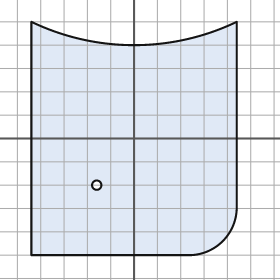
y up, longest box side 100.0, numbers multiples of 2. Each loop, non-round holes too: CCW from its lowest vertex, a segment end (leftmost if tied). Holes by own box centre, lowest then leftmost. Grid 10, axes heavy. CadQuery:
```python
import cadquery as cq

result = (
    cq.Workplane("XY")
    .moveTo(-44.0, -50.0)
    .lineTo(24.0, -50.0)
    .threePointArc((38.0, -44.0), (44.0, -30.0))
    .lineTo(44.0, 50.0)
    .threePointArc((0.0, 40.0), (-44.0, 50.0))
    .close()
    .moveTo(-16.0, -20.0)
    .circle(2.0)
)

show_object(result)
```